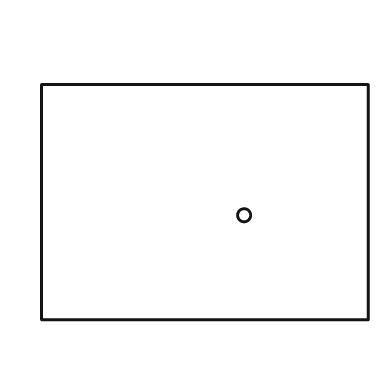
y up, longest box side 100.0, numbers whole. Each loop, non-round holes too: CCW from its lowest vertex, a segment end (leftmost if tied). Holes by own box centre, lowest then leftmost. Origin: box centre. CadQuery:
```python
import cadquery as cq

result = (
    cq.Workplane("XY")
    .moveTo(-50.0, -36.0)
    .lineTo(50.0, -36.0)
    .lineTo(50.0, 36.0)
    .lineTo(-50.0, 36.0)
    .close()
    .moveTo(12.0, -4.0)
    .circle(2.0)
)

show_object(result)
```